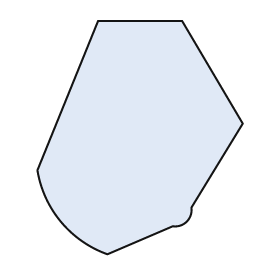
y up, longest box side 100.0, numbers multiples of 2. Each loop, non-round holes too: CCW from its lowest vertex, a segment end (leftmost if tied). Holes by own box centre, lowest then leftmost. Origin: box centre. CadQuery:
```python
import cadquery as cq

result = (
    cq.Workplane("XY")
    .moveTo(-14.0, -50.0)
    .lineTo(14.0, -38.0)
    .threePointArc((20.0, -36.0), (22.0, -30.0))
    .lineTo(44.0, 6.0)
    .lineTo(18.0, 50.0)
    .lineTo(-18.0, 50.0)
    .lineTo(-44.0, -14.0)
    .threePointArc((-34.0, -36.0), (-14.0, -50.0))
    .close()
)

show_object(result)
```